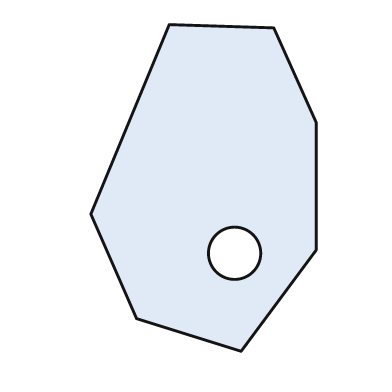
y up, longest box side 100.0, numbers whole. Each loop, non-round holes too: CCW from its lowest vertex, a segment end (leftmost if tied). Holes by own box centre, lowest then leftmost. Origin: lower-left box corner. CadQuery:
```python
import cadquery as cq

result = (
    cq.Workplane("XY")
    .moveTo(46.0, 0.0)
    .lineTo(69.0, 31.0)
    .lineTo(69.0, 70.0)
    .lineTo(56.0, 99.0)
    .lineTo(24.0, 100.0)
    .lineTo(0.0, 42.0)
    .lineTo(14.0, 10.0)
    .close()
    .moveTo(44.0, 30.0)
    .circle(8.0)
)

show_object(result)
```